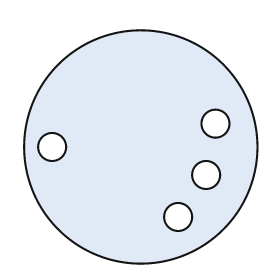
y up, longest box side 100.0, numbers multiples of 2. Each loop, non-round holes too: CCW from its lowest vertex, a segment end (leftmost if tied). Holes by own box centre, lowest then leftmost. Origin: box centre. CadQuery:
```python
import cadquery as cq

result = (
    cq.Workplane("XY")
    .moveTo(0.0, 0.0)
    .circle(50.0)
    .moveTo(16.0, -30.0)
    .circle(6.0)
    .moveTo(28.0, -12.0)
    .circle(6.0)
    .moveTo(-38.0, 0.0)
    .circle(6.0)
    .moveTo(32.0, 10.0)
    .circle(6.0)
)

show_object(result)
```